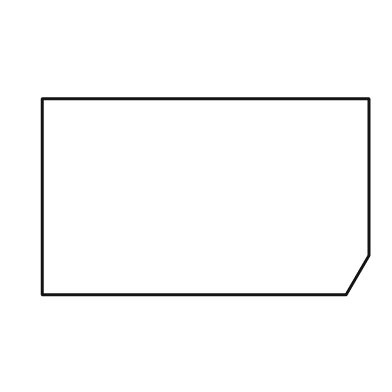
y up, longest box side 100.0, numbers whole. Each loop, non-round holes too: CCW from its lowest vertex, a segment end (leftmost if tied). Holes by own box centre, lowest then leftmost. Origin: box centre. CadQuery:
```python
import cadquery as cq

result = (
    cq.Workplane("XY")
    .moveTo(-50.0, -30.0)
    .lineTo(43.0, -30.0)
    .lineTo(50.0, -18.0)
    .lineTo(50.0, 30.0)
    .lineTo(-50.0, 30.0)
    .close()
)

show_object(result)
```